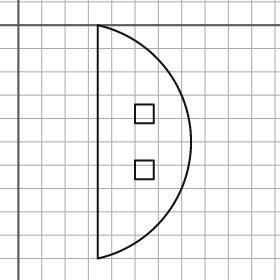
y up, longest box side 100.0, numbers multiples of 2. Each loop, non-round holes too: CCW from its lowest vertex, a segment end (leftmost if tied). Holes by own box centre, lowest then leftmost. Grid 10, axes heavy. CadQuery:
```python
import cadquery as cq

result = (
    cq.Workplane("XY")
    .moveTo(34.0, -100.0)
    .threePointArc((74.0, -50.0), (34.0, 0.0))
    .close()
    .moveTo(50.0, -66.0)
    .lineTo(58.0, -66.0)
    .lineTo(58.0, -58.0)
    .lineTo(50.0, -58.0)
    .close()
    .moveTo(50.0, -42.0)
    .lineTo(58.0, -42.0)
    .lineTo(58.0, -34.0)
    .lineTo(50.0, -34.0)
    .close()
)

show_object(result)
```